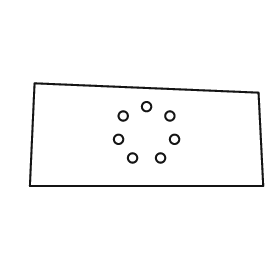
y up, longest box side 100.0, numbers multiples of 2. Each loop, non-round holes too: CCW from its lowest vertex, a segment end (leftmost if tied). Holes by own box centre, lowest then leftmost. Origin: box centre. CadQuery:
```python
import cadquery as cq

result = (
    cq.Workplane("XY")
    .moveTo(-50.0, -22.0)
    .lineTo(50.0, -22.0)
    .lineTo(48.0, 18.0)
    .lineTo(-48.0, 22.0)
    .close()
    .moveTo(-6.0, -10.0)
    .circle(2.0)
    .moveTo(6.0, -10.0)
    .circle(2.0)
    .moveTo(-12.0, -2.0)
    .circle(2.0)
    .moveTo(12.0, -2.0)
    .circle(2.0)
    .moveTo(-10.0, 8.0)
    .circle(2.0)
    .moveTo(10.0, 8.0)
    .circle(2.0)
    .moveTo(0.0, 12.0)
    .circle(2.0)
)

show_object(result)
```